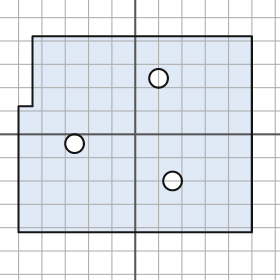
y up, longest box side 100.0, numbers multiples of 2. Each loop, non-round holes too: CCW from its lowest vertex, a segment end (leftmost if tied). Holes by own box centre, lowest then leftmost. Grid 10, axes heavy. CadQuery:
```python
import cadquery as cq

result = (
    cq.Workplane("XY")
    .moveTo(-50.0, -42.0)
    .lineTo(50.0, -42.0)
    .lineTo(50.0, 42.0)
    .lineTo(-44.0, 42.0)
    .lineTo(-44.0, 12.0)
    .lineTo(-50.0, 12.0)
    .close()
    .moveTo(16.0, -20.0)
    .circle(4.0)
    .moveTo(-26.0, -4.0)
    .circle(4.0)
    .moveTo(10.0, 24.0)
    .circle(4.0)
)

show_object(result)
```